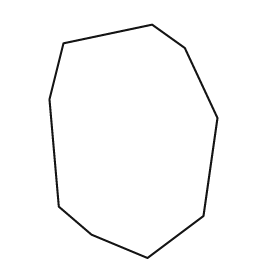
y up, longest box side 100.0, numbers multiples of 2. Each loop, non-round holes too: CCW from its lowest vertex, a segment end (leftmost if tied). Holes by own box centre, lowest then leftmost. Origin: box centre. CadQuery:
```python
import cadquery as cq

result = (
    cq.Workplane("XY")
    .moveTo(6.0, -50.0)
    .lineTo(30.0, -32.0)
    .lineTo(36.0, 10.0)
    .lineTo(22.0, 40.0)
    .lineTo(8.0, 50.0)
    .lineTo(-30.0, 42.0)
    .lineTo(-36.0, 18.0)
    .lineTo(-32.0, -28.0)
    .lineTo(-18.0, -40.0)
    .close()
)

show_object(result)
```